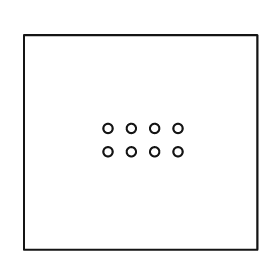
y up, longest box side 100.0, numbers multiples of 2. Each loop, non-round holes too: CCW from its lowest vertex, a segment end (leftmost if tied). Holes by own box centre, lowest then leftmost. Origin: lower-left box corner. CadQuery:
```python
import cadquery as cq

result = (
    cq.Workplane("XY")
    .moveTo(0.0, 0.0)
    .lineTo(100.0, 0.0)
    .lineTo(100.0, 92.0)
    .lineTo(0.0, 92.0)
    .close()
    .moveTo(36.0, 42.0)
    .circle(2.0)
    .moveTo(46.0, 42.0)
    .circle(2.0)
    .moveTo(56.0, 42.0)
    .circle(2.0)
    .moveTo(66.0, 42.0)
    .circle(2.0)
    .moveTo(36.0, 52.0)
    .circle(2.0)
    .moveTo(46.0, 52.0)
    .circle(2.0)
    .moveTo(56.0, 52.0)
    .circle(2.0)
    .moveTo(66.0, 52.0)
    .circle(2.0)
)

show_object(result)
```